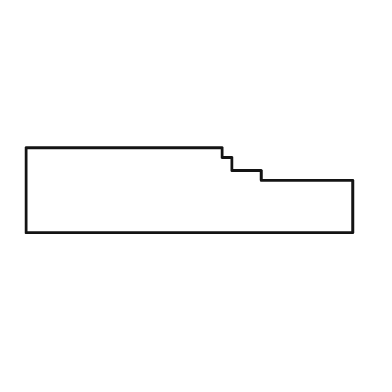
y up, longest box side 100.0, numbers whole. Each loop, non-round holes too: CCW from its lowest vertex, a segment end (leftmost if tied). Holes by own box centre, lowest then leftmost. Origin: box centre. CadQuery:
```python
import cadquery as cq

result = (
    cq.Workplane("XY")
    .moveTo(-50.0, -13.0)
    .lineTo(50.0, -13.0)
    .lineTo(50.0, 3.0)
    .lineTo(22.0, 3.0)
    .lineTo(22.0, 6.0)
    .lineTo(13.0, 6.0)
    .lineTo(13.0, 10.0)
    .lineTo(10.0, 10.0)
    .lineTo(10.0, 13.0)
    .lineTo(-50.0, 13.0)
    .close()
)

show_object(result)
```